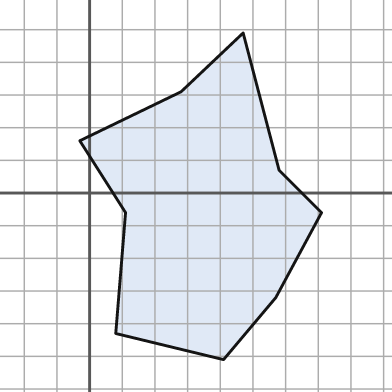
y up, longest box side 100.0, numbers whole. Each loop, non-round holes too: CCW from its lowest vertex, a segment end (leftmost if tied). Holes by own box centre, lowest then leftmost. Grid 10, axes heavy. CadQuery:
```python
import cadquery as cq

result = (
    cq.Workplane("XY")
    .moveTo(41.0, -51.0)
    .lineTo(57.0, -32.0)
    .lineTo(71.0, -6.0)
    .lineTo(58.0, 7.0)
    .lineTo(47.0, 49.0)
    .lineTo(28.0, 31.0)
    .lineTo(-3.0, 16.0)
    .lineTo(11.0, -6.0)
    .lineTo(8.0, -43.0)
    .close()
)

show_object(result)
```